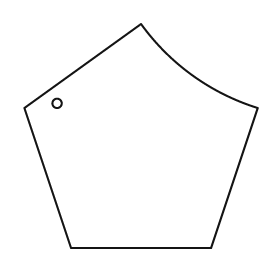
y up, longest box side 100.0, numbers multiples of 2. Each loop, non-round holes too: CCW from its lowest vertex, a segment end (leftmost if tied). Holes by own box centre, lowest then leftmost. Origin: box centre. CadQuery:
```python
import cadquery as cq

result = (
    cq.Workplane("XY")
    .moveTo(-30.0, -48.0)
    .lineTo(30.0, -48.0)
    .lineTo(50.0, 12.0)
    .threePointArc((22.0, 26.0), (0.0, 48.0))
    .lineTo(-50.0, 12.0)
    .close()
    .moveTo(-36.0, 14.0)
    .circle(2.0)
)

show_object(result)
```